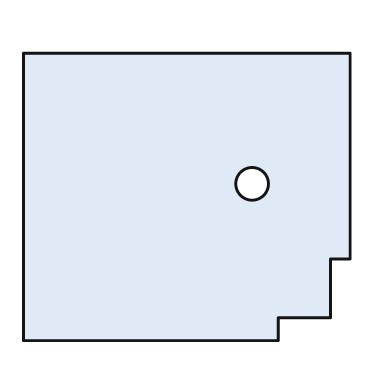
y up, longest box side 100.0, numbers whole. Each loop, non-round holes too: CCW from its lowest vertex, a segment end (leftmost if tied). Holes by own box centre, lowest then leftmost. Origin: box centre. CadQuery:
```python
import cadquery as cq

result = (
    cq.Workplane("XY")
    .moveTo(-50.0, -44.0)
    .lineTo(28.0, -44.0)
    .lineTo(28.0, -37.0)
    .lineTo(44.0, -37.0)
    .lineTo(44.0, -19.0)
    .lineTo(50.0, -19.0)
    .lineTo(50.0, 44.0)
    .lineTo(-50.0, 44.0)
    .close()
    .moveTo(20.0, 4.0)
    .circle(5.0)
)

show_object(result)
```